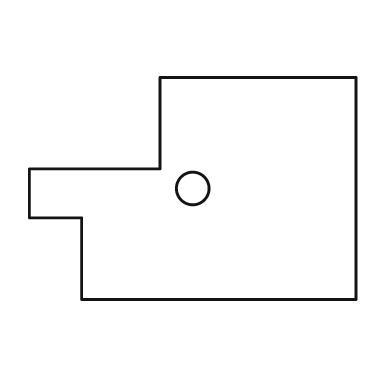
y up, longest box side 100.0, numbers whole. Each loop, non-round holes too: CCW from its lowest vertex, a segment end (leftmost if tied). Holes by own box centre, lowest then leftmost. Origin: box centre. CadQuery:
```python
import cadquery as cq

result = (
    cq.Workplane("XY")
    .moveTo(-34.0, -34.0)
    .lineTo(50.0, -34.0)
    .lineTo(50.0, 34.0)
    .lineTo(-10.0, 34.0)
    .lineTo(-10.0, 6.0)
    .lineTo(-50.0, 6.0)
    .lineTo(-50.0, -9.0)
    .lineTo(-34.0, -9.0)
    .close()
    .moveTo(0.0, 0.0)
    .circle(5.0)
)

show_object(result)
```